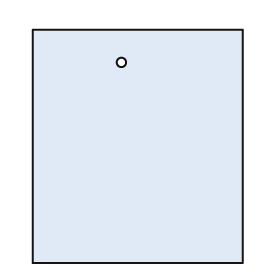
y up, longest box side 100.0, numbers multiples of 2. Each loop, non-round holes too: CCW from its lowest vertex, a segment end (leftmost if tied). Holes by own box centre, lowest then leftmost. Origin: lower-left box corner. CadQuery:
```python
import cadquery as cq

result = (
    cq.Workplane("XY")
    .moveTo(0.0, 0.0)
    .lineTo(90.0, 0.0)
    .lineTo(90.0, 100.0)
    .lineTo(0.0, 100.0)
    .close()
    .moveTo(38.0, 86.0)
    .circle(2.0)
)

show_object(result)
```